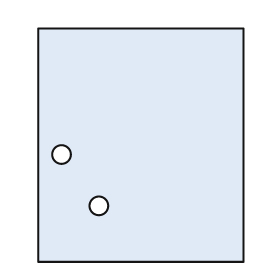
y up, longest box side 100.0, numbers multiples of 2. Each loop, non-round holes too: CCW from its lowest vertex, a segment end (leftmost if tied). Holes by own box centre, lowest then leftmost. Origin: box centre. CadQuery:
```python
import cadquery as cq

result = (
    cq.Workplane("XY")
    .moveTo(-44.0, -50.0)
    .lineTo(44.0, -50.0)
    .lineTo(44.0, 50.0)
    .lineTo(-44.0, 50.0)
    .close()
    .moveTo(-18.0, -26.0)
    .circle(4.0)
    .moveTo(-34.0, -4.0)
    .circle(4.0)
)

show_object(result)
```